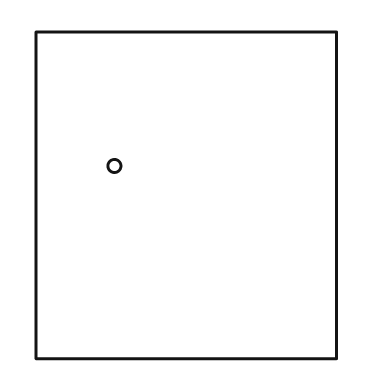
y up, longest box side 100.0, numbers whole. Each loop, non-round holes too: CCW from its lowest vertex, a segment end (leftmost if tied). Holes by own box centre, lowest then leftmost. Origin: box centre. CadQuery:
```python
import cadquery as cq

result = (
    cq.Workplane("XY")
    .moveTo(-46.0, -50.0)
    .lineTo(46.0, -50.0)
    .lineTo(46.0, 50.0)
    .lineTo(-46.0, 50.0)
    .close()
    .moveTo(-22.0, 9.0)
    .circle(2.0)
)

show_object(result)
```